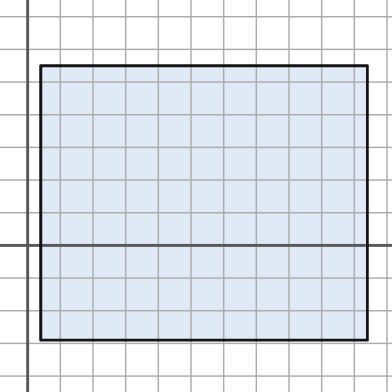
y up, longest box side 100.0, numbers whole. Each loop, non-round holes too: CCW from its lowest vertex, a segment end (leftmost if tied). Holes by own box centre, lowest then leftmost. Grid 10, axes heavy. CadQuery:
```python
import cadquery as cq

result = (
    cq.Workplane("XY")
    .moveTo(4.0, -29.0)
    .lineTo(104.0, -29.0)
    .lineTo(104.0, 55.0)
    .lineTo(4.0, 55.0)
    .close()
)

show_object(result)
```